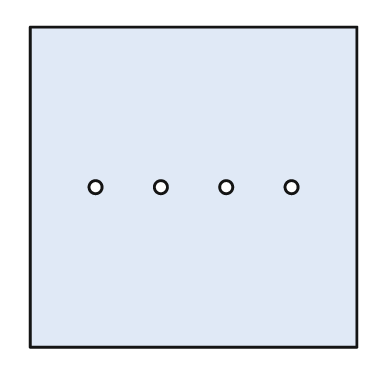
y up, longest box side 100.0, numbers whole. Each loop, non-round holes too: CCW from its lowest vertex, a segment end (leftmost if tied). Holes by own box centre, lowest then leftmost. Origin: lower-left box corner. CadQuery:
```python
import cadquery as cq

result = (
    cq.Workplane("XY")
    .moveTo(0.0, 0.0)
    .lineTo(100.0, 0.0)
    .lineTo(100.0, 98.0)
    .lineTo(0.0, 98.0)
    .close()
    .moveTo(20.0, 49.0)
    .circle(2.0)
    .moveTo(40.0, 49.0)
    .circle(2.0)
    .moveTo(60.0, 49.0)
    .circle(2.0)
    .moveTo(80.0, 49.0)
    .circle(2.0)
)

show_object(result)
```